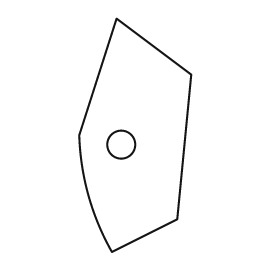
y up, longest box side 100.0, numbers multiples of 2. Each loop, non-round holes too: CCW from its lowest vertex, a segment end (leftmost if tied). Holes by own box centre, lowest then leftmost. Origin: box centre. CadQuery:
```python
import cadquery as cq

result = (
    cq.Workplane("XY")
    .moveTo(-10.0, -50.0)
    .lineTo(18.0, -36.0)
    .lineTo(24.0, 26.0)
    .lineTo(-8.0, 50.0)
    .lineTo(-24.0, 0.0)
    .threePointArc((-20.0, -26.0), (-10.0, -50.0))
    .close()
    .moveTo(-6.0, -4.0)
    .circle(6.0)
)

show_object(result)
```